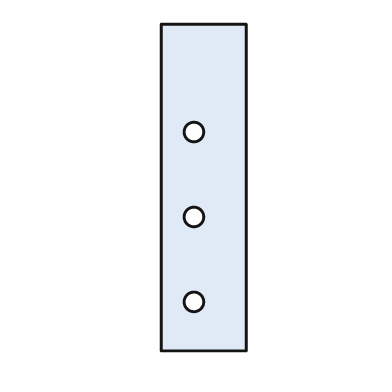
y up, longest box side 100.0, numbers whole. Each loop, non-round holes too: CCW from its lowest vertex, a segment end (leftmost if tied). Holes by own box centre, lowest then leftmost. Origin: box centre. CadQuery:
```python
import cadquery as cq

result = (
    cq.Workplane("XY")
    .moveTo(-13.0, -50.0)
    .lineTo(13.0, -50.0)
    .lineTo(13.0, 50.0)
    .lineTo(-13.0, 50.0)
    .close()
    .moveTo(-3.0, -35.0)
    .circle(3.0)
    .moveTo(-3.0, -9.0)
    .circle(3.0)
    .moveTo(-3.0, 17.0)
    .circle(3.0)
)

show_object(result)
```